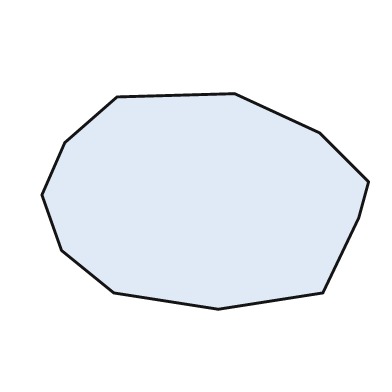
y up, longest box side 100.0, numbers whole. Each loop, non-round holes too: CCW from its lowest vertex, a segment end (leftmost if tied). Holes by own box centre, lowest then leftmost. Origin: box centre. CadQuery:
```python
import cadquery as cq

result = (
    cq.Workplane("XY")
    .moveTo(4.0, -33.0)
    .lineTo(36.0, -28.0)
    .lineTo(47.0, -5.0)
    .lineTo(50.0, 6.0)
    .lineTo(35.0, 21.0)
    .lineTo(9.0, 33.0)
    .lineTo(-27.0, 32.0)
    .lineTo(-43.0, 18.0)
    .lineTo(-50.0, 2.0)
    .lineTo(-44.0, -15.0)
    .lineTo(-28.0, -28.0)
    .close()
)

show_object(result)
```